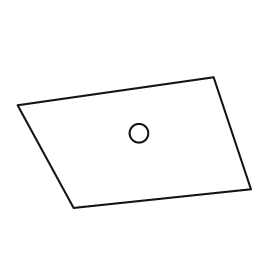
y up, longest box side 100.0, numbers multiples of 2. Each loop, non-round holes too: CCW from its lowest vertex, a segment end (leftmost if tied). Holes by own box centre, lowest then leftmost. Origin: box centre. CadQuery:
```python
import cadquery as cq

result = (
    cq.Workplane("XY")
    .moveTo(-26.0, -28.0)
    .lineTo(50.0, -20.0)
    .lineTo(34.0, 28.0)
    .lineTo(-50.0, 16.0)
    .close()
    .moveTo(2.0, 4.0)
    .circle(4.0)
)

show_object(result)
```